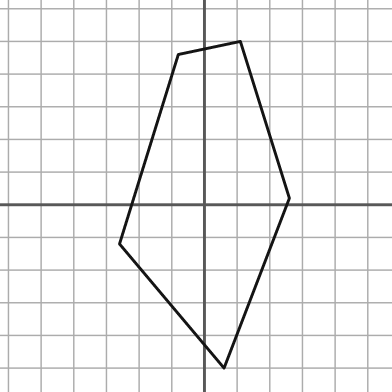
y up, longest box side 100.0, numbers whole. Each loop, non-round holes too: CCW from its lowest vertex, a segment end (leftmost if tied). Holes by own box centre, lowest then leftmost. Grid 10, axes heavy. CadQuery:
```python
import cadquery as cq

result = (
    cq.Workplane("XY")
    .moveTo(6.0, -50.0)
    .lineTo(26.0, 2.0)
    .lineTo(11.0, 50.0)
    .lineTo(-8.0, 46.0)
    .lineTo(-26.0, -12.0)
    .close()
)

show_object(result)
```